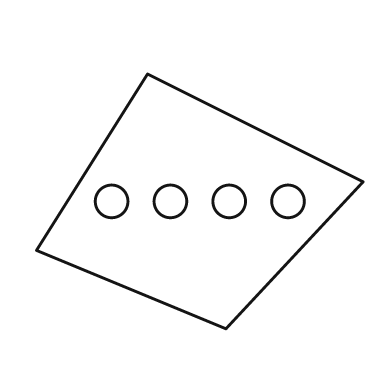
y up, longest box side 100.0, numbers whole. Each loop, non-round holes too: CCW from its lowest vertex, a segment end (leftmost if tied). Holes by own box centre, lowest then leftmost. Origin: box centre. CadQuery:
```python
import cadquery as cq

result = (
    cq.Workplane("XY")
    .moveTo(8.0, -39.0)
    .lineTo(50.0, 6.0)
    .lineTo(-16.0, 39.0)
    .lineTo(-50.0, -15.0)
    .close()
    .moveTo(-27.0, 0.0)
    .circle(5.0)
    .moveTo(-9.0, 0.0)
    .circle(5.0)
    .moveTo(9.0, 0.0)
    .circle(5.0)
    .moveTo(27.0, 0.0)
    .circle(5.0)
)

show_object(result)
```